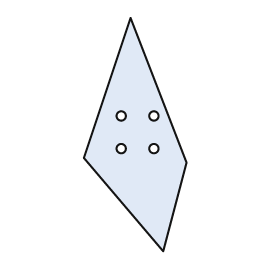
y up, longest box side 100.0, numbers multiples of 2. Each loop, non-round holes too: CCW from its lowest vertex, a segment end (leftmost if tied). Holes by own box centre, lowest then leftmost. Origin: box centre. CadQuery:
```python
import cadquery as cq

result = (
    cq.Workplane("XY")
    .moveTo(12.0, -50.0)
    .lineTo(22.0, -12.0)
    .lineTo(-2.0, 50.0)
    .lineTo(-22.0, -10.0)
    .close()
    .moveTo(-6.0, -6.0)
    .circle(2.0)
    .moveTo(8.0, -6.0)
    .circle(2.0)
    .moveTo(-6.0, 8.0)
    .circle(2.0)
    .moveTo(8.0, 8.0)
    .circle(2.0)
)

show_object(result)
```